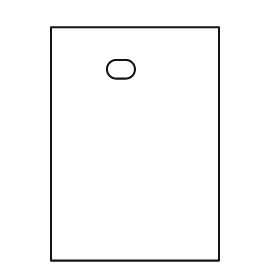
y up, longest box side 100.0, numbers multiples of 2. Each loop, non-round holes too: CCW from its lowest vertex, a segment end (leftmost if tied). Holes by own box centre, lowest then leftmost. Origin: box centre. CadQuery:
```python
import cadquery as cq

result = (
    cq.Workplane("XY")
    .moveTo(-36.0, -50.0)
    .lineTo(36.0, -50.0)
    .lineTo(36.0, 50.0)
    .lineTo(-36.0, 50.0)
    .close()
    .moveTo(-8.0, 28.0)
    .lineTo(-4.0, 28.0)
    .threePointArc((0.0, 32.0), (-4.0, 36.0))
    .lineTo(-8.0, 36.0)
    .threePointArc((-12.0, 32.0), (-8.0, 28.0))
    .close()
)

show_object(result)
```